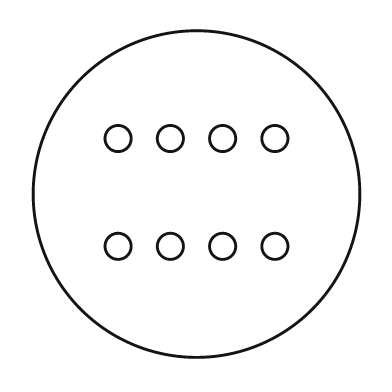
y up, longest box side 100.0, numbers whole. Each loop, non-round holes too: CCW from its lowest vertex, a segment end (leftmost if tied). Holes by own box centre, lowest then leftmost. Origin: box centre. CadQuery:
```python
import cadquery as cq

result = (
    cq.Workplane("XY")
    .moveTo(0.0, 0.0)
    .circle(50.0)
    .moveTo(-24.0, -16.0)
    .circle(4.0)
    .moveTo(-8.0, -16.0)
    .circle(4.0)
    .moveTo(8.0, -16.0)
    .circle(4.0)
    .moveTo(24.0, -16.0)
    .circle(4.0)
    .moveTo(-24.0, 17.0)
    .circle(4.0)
    .moveTo(-8.0, 17.0)
    .circle(4.0)
    .moveTo(8.0, 17.0)
    .circle(4.0)
    .moveTo(24.0, 17.0)
    .circle(4.0)
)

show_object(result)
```